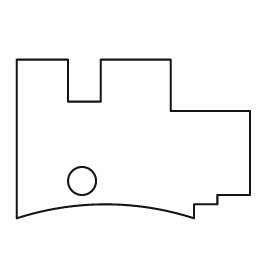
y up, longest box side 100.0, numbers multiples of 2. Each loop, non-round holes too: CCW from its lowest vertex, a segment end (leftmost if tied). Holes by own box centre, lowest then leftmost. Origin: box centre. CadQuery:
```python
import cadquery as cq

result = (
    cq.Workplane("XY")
    .moveTo(-50.0, -34.0)
    .threePointArc((-12.0, -28.0), (26.0, -34.0))
    .lineTo(26.0, -28.0)
    .lineTo(36.0, -28.0)
    .lineTo(36.0, -24.0)
    .lineTo(50.0, -24.0)
    .lineTo(50.0, 12.0)
    .lineTo(16.0, 12.0)
    .lineTo(16.0, 34.0)
    .lineTo(-14.0, 34.0)
    .lineTo(-14.0, 16.0)
    .lineTo(-28.0, 16.0)
    .lineTo(-28.0, 34.0)
    .lineTo(-50.0, 34.0)
    .close()
    .moveTo(-22.0, -18.0)
    .circle(6.0)
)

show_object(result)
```